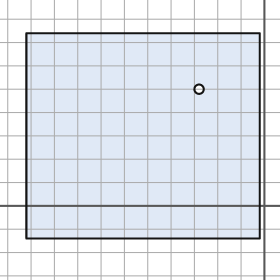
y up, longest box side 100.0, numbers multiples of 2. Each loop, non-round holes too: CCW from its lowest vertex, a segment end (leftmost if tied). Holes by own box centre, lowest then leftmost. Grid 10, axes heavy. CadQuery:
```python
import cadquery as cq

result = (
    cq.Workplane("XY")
    .moveTo(-102.0, -14.0)
    .lineTo(-2.0, -14.0)
    .lineTo(-2.0, 74.0)
    .lineTo(-102.0, 74.0)
    .close()
    .moveTo(-28.0, 50.0)
    .circle(2.0)
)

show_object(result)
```